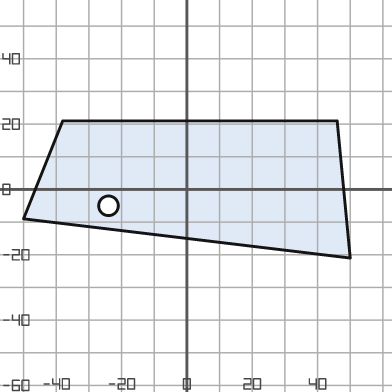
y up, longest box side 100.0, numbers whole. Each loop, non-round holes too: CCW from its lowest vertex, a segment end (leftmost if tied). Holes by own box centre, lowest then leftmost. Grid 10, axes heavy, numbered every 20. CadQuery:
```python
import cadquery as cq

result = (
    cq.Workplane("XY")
    .moveTo(50.0, -21.0)
    .lineTo(46.0, 21.0)
    .lineTo(-38.0, 21.0)
    .lineTo(-50.0, -9.0)
    .close()
    .moveTo(-24.0, -5.0)
    .circle(3.0)
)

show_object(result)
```